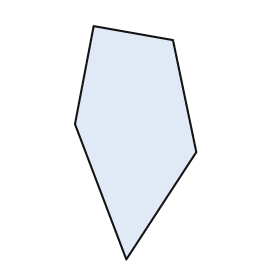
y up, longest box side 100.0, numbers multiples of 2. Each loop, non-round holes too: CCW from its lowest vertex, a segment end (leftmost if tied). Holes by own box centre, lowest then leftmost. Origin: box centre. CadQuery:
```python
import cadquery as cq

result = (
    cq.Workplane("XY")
    .moveTo(-4.0, -50.0)
    .lineTo(26.0, -4.0)
    .lineTo(16.0, 44.0)
    .lineTo(-18.0, 50.0)
    .lineTo(-26.0, 8.0)
    .close()
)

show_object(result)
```